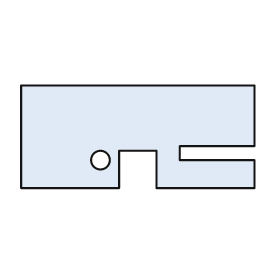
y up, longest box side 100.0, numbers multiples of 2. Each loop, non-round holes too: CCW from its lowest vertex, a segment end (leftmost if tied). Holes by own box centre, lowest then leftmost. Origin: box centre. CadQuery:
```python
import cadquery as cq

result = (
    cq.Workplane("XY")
    .moveTo(-50.0, -22.0)
    .lineTo(-8.0, -22.0)
    .lineTo(-8.0, -6.0)
    .lineTo(8.0, -6.0)
    .lineTo(8.0, -22.0)
    .lineTo(50.0, -22.0)
    .lineTo(50.0, -10.0)
    .lineTo(18.0, -10.0)
    .lineTo(18.0, -4.0)
    .lineTo(50.0, -4.0)
    .lineTo(50.0, 22.0)
    .lineTo(-50.0, 22.0)
    .close()
    .moveTo(-16.0, -10.0)
    .circle(4.0)
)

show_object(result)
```